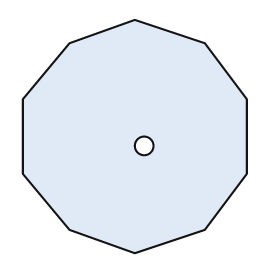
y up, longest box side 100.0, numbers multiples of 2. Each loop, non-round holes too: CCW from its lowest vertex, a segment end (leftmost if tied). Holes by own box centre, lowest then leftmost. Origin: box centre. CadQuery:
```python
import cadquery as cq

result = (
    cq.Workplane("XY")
    .moveTo(0.0, -50.0)
    .lineTo(30.0, -40.0)
    .lineTo(48.0, -16.0)
    .lineTo(48.0, 16.0)
    .lineTo(30.0, 40.0)
    .lineTo(0.0, 50.0)
    .lineTo(-28.0, 40.0)
    .lineTo(-48.0, 16.0)
    .lineTo(-48.0, -16.0)
    .lineTo(-28.0, -40.0)
    .close()
    .moveTo(4.0, -4.0)
    .circle(4.0)
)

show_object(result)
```